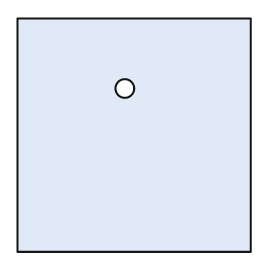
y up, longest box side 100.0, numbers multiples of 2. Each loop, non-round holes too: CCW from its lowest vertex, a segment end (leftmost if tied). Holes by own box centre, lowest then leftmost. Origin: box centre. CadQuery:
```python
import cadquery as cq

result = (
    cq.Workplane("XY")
    .moveTo(-50.0, -50.0)
    .lineTo(50.0, -50.0)
    .lineTo(50.0, 50.0)
    .lineTo(-50.0, 50.0)
    .close()
    .moveTo(-4.0, 20.0)
    .circle(4.0)
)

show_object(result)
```